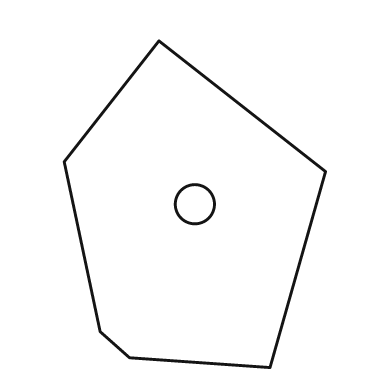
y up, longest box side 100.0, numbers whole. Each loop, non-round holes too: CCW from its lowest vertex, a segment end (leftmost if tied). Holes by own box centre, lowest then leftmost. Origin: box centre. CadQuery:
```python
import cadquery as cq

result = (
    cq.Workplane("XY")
    .moveTo(23.0, -50.0)
    .lineTo(40.0, 10.0)
    .lineTo(-11.0, 50.0)
    .lineTo(-40.0, 13.0)
    .lineTo(-29.0, -39.0)
    .lineTo(-20.0, -47.0)
    .close()
    .moveTo(0.0, 0.0)
    .circle(6.0)
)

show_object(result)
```